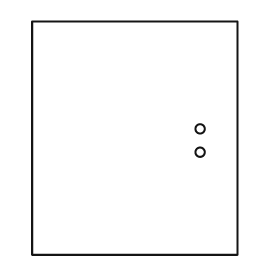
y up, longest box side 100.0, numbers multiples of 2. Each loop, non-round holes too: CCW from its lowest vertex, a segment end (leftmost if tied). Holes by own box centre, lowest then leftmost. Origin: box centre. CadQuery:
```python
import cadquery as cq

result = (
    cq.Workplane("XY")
    .moveTo(-44.0, -50.0)
    .lineTo(44.0, -50.0)
    .lineTo(44.0, 50.0)
    .lineTo(-44.0, 50.0)
    .close()
    .moveTo(28.0, -6.0)
    .circle(2.0)
    .moveTo(28.0, 4.0)
    .circle(2.0)
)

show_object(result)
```